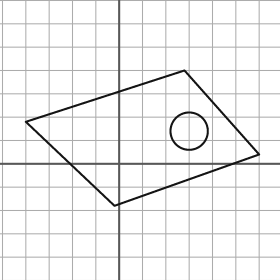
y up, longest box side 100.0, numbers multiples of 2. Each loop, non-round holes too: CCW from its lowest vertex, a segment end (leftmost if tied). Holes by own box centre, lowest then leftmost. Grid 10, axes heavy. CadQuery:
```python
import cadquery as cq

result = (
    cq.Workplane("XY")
    .moveTo(-2.0, -18.0)
    .lineTo(60.0, 4.0)
    .lineTo(28.0, 40.0)
    .lineTo(-40.0, 18.0)
    .close()
    .moveTo(30.0, 14.0)
    .circle(8.0)
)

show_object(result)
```